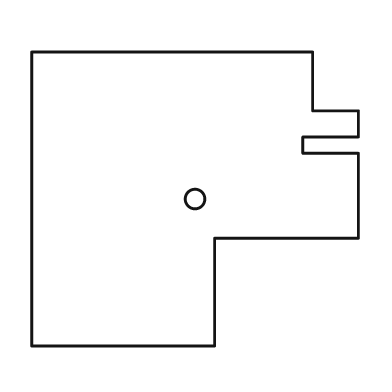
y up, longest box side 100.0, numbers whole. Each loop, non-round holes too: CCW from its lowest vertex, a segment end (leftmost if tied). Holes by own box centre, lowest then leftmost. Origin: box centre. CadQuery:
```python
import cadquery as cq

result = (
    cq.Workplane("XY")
    .moveTo(-50.0, -45.0)
    .lineTo(6.0, -45.0)
    .lineTo(6.0, -12.0)
    .lineTo(50.0, -12.0)
    .lineTo(50.0, 14.0)
    .lineTo(33.0, 14.0)
    .lineTo(33.0, 19.0)
    .lineTo(50.0, 19.0)
    .lineTo(50.0, 27.0)
    .lineTo(36.0, 27.0)
    .lineTo(36.0, 45.0)
    .lineTo(-50.0, 45.0)
    .close()
    .moveTo(0.0, 0.0)
    .circle(3.0)
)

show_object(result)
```